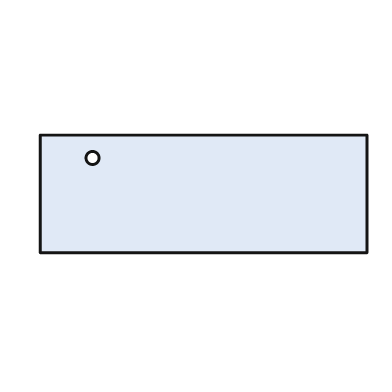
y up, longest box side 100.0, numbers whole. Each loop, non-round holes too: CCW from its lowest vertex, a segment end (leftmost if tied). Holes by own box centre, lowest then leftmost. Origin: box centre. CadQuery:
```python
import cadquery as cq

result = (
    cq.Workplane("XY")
    .moveTo(-50.0, -18.0)
    .lineTo(50.0, -18.0)
    .lineTo(50.0, 18.0)
    .lineTo(-50.0, 18.0)
    .close()
    .moveTo(-34.0, 11.0)
    .circle(2.0)
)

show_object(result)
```